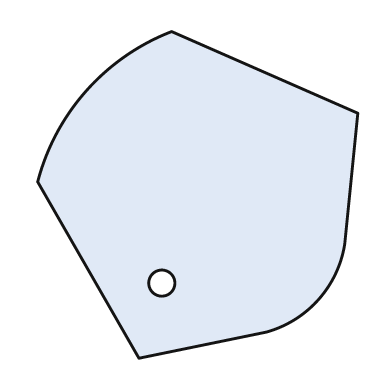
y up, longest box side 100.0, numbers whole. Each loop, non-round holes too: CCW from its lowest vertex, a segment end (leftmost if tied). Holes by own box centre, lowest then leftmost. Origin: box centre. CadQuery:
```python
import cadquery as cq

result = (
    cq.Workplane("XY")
    .moveTo(-18.0, -50.0)
    .lineTo(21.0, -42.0)
    .threePointArc((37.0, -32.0), (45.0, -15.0))
    .lineTo(49.0, 25.0)
    .lineTo(-8.0, 50.0)
    .threePointArc((-34.0, 32.0), (-49.0, 4.0))
    .close()
    .moveTo(-11.0, -27.0)
    .circle(4.0)
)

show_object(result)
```